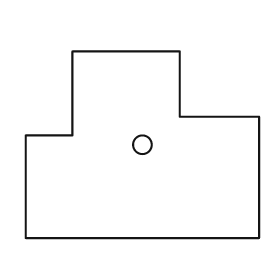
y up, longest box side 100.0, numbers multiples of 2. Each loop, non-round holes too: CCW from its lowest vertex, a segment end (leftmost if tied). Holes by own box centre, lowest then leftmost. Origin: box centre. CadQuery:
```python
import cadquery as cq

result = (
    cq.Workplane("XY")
    .moveTo(-50.0, -40.0)
    .lineTo(50.0, -40.0)
    .lineTo(50.0, 12.0)
    .lineTo(16.0, 12.0)
    .lineTo(16.0, 40.0)
    .lineTo(-30.0, 40.0)
    .lineTo(-30.0, 4.0)
    .lineTo(-50.0, 4.0)
    .close()
    .moveTo(0.0, 0.0)
    .circle(4.0)
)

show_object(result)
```